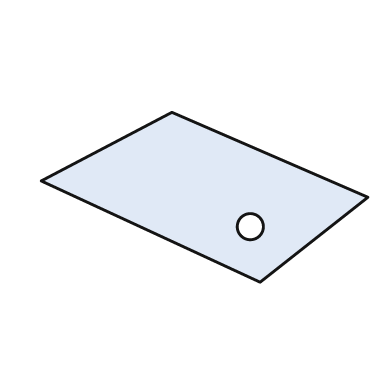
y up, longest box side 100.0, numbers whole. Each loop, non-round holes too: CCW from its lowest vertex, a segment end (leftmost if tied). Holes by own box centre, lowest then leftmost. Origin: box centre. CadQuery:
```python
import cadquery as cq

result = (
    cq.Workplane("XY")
    .moveTo(17.0, -26.0)
    .lineTo(50.0, 0.0)
    .lineTo(-10.0, 26.0)
    .lineTo(-50.0, 5.0)
    .close()
    .moveTo(14.0, -9.0)
    .circle(4.0)
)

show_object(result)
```